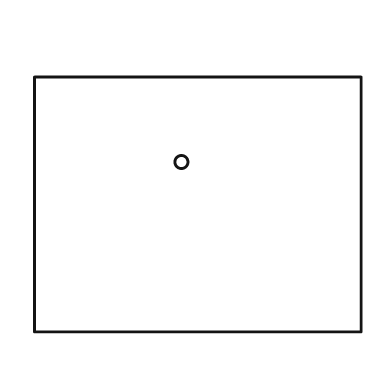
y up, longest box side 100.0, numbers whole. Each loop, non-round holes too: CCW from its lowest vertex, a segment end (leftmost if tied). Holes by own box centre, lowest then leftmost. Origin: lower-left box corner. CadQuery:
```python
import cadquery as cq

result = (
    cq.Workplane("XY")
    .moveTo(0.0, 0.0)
    .lineTo(100.0, 0.0)
    .lineTo(100.0, 78.0)
    .lineTo(0.0, 78.0)
    .close()
    .moveTo(45.0, 52.0)
    .circle(2.0)
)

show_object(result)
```